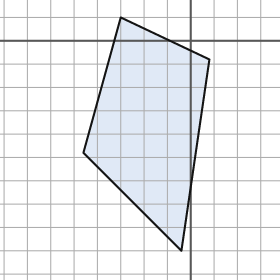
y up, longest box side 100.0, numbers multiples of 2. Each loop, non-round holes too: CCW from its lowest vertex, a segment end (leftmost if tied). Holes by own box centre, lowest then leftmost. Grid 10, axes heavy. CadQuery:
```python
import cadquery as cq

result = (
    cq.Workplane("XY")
    .moveTo(-4.0, -90.0)
    .lineTo(8.0, -8.0)
    .lineTo(-30.0, 10.0)
    .lineTo(-46.0, -48.0)
    .close()
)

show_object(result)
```